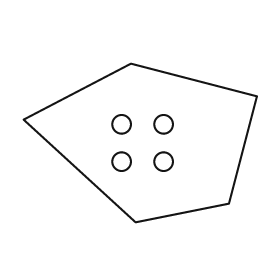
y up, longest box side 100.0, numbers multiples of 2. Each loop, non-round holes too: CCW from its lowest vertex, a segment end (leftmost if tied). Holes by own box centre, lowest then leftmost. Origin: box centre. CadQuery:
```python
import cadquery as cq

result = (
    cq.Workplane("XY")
    .moveTo(-2.0, -34.0)
    .lineTo(38.0, -26.0)
    .lineTo(50.0, 20.0)
    .lineTo(-4.0, 34.0)
    .lineTo(-50.0, 10.0)
    .close()
    .moveTo(-8.0, -8.0)
    .circle(4.0)
    .moveTo(10.0, -8.0)
    .circle(4.0)
    .moveTo(-8.0, 8.0)
    .circle(4.0)
    .moveTo(10.0, 8.0)
    .circle(4.0)
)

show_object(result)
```